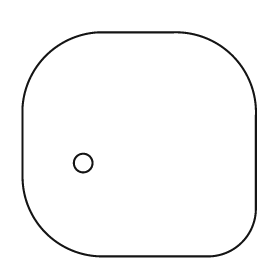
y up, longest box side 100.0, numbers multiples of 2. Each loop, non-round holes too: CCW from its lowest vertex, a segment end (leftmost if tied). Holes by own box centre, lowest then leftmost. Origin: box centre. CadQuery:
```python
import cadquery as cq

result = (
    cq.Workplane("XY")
    .moveTo(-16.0, -48.0)
    .lineTo(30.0, -48.0)
    .threePointArc((44.0, -42.0), (50.0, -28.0))
    .lineTo(50.0, 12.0)
    .threePointArc((40.0, 38.0), (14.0, 48.0))
    .lineTo(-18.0, 48.0)
    .threePointArc((-40.0, 38.0), (-50.0, 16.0))
    .lineTo(-50.0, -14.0)
    .threePointArc((-40.0, -38.0), (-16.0, -48.0))
    .close()
    .moveTo(-24.0, -8.0)
    .circle(4.0)
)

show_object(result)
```